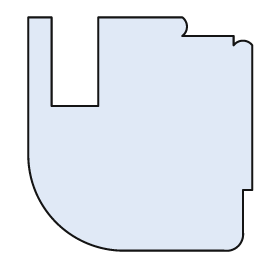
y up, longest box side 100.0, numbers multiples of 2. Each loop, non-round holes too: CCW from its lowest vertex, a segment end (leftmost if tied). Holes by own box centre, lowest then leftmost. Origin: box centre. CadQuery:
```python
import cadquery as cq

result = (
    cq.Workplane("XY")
    .moveTo(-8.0, -50.0)
    .lineTo(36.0, -50.0)
    .threePointArc((42.0, -48.0), (44.0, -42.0))
    .lineTo(44.0, -24.0)
    .lineTo(48.0, -24.0)
    .lineTo(48.0, 38.0)
    .threePointArc((44.0, 40.0), (40.0, 38.0))
    .lineTo(40.0, 42.0)
    .lineTo(18.0, 42.0)
    .threePointArc((20.0, 46.0), (18.0, 50.0))
    .lineTo(-18.0, 50.0)
    .lineTo(-18.0, 12.0)
    .lineTo(-38.0, 12.0)
    .lineTo(-38.0, 50.0)
    .lineTo(-48.0, 50.0)
    .lineTo(-48.0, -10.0)
    .threePointArc((-36.0, -38.0), (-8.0, -50.0))
    .close()
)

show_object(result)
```